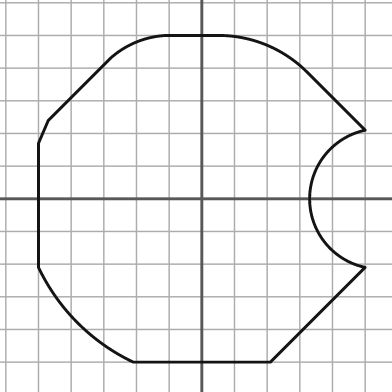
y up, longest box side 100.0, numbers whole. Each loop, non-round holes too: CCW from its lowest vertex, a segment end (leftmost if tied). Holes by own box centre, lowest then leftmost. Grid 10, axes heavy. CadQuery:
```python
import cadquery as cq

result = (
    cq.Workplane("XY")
    .moveTo(-21.0, -50.0)
    .lineTo(21.0, -50.0)
    .lineTo(50.0, -21.0)
    .threePointArc((33.0, 0.0), (50.0, 21.0))
    .lineTo(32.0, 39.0)
    .threePointArc((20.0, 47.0), (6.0, 50.0))
    .lineTo(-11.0, 50.0)
    .threePointArc((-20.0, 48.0), (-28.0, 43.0))
    .lineTo(-47.0, 24.0)
    .lineTo(-50.0, 17.0)
    .lineTo(-50.0, -21.0)
    .threePointArc((-38.0, -38.0), (-21.0, -50.0))
    .close()
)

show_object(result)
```